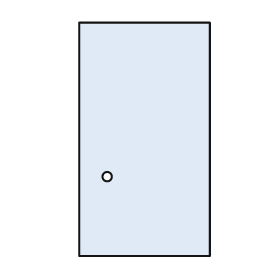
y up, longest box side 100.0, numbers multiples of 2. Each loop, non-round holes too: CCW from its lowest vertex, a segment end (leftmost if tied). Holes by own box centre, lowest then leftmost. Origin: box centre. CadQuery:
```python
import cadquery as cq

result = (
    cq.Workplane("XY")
    .moveTo(-28.0, -50.0)
    .lineTo(28.0, -50.0)
    .lineTo(28.0, 50.0)
    .lineTo(-28.0, 50.0)
    .close()
    .moveTo(-16.0, -16.0)
    .circle(2.0)
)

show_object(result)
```